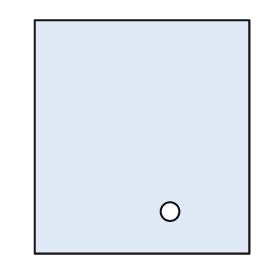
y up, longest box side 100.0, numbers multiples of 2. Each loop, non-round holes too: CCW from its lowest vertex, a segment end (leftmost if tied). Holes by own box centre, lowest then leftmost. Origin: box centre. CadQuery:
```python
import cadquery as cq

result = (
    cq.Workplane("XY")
    .moveTo(-46.0, -50.0)
    .lineTo(46.0, -50.0)
    .lineTo(46.0, 50.0)
    .lineTo(-46.0, 50.0)
    .close()
    .moveTo(12.0, -32.0)
    .circle(4.0)
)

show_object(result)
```